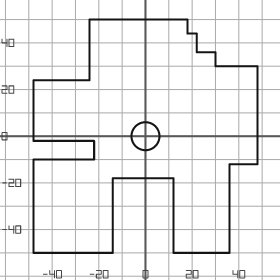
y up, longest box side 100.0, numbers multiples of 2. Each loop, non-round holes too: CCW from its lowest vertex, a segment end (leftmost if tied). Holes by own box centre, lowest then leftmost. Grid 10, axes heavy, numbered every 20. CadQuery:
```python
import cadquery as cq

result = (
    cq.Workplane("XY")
    .moveTo(-48.0, -50.0)
    .lineTo(-14.0, -50.0)
    .lineTo(-14.0, -18.0)
    .lineTo(12.0, -18.0)
    .lineTo(12.0, -50.0)
    .lineTo(36.0, -50.0)
    .lineTo(36.0, -12.0)
    .lineTo(48.0, -12.0)
    .lineTo(48.0, 30.0)
    .lineTo(30.0, 30.0)
    .lineTo(30.0, 36.0)
    .lineTo(22.0, 36.0)
    .lineTo(22.0, 44.0)
    .lineTo(18.0, 44.0)
    .lineTo(18.0, 50.0)
    .lineTo(-24.0, 50.0)
    .lineTo(-24.0, 24.0)
    .lineTo(-48.0, 24.0)
    .lineTo(-48.0, -2.0)
    .lineTo(-22.0, -2.0)
    .lineTo(-22.0, -10.0)
    .lineTo(-48.0, -10.0)
    .close()
    .moveTo(0.0, 0.0)
    .circle(6.0)
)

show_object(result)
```